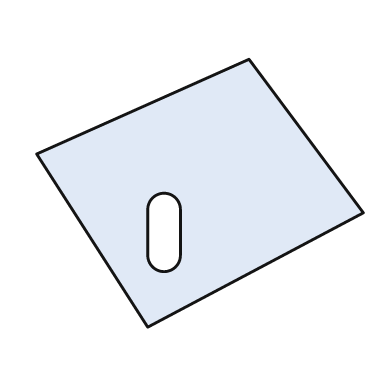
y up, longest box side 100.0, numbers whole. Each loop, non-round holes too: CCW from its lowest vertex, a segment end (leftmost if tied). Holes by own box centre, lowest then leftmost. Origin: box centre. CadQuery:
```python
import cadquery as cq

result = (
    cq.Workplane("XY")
    .moveTo(-16.0, -41.0)
    .lineTo(50.0, -6.0)
    .lineTo(15.0, 41.0)
    .lineTo(-50.0, 12.0)
    .close()
    .moveTo(-16.0, -19.0)
    .threePointArc((-11.0, -24.0), (-6.0, -19.0))
    .lineTo(-6.0, -5.0)
    .threePointArc((-11.0, 0.0), (-16.0, -5.0))
    .close()
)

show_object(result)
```